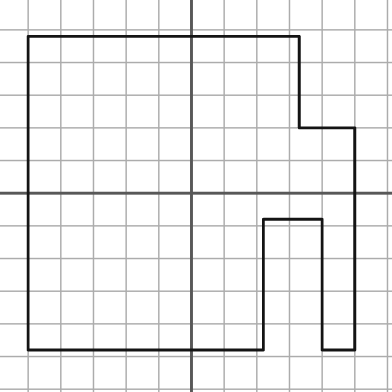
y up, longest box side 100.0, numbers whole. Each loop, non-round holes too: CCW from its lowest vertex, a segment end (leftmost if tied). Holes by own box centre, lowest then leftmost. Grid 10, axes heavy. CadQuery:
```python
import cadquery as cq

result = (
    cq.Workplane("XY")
    .moveTo(-50.0, -48.0)
    .lineTo(22.0, -48.0)
    .lineTo(22.0, -8.0)
    .lineTo(40.0, -8.0)
    .lineTo(40.0, -48.0)
    .lineTo(50.0, -48.0)
    .lineTo(50.0, 20.0)
    .lineTo(33.0, 20.0)
    .lineTo(33.0, 48.0)
    .lineTo(-50.0, 48.0)
    .close()
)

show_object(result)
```